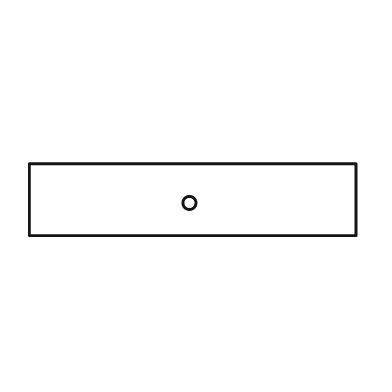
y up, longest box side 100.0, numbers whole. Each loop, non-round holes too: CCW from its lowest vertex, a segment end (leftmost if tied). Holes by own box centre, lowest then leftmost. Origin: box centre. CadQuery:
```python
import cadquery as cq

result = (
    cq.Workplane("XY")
    .moveTo(-50.0, -11.0)
    .lineTo(50.0, -11.0)
    .lineTo(50.0, 11.0)
    .lineTo(-50.0, 11.0)
    .close()
    .moveTo(-1.0, -1.0)
    .circle(2.0)
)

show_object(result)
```